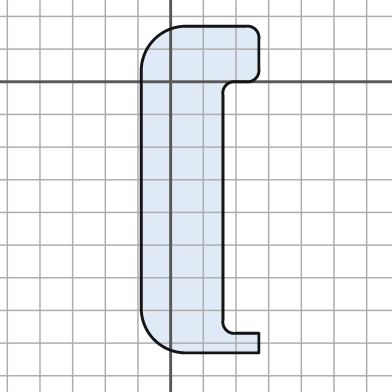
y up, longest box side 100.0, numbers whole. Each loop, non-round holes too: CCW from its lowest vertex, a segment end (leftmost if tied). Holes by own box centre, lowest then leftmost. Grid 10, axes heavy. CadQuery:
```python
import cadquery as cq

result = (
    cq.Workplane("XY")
    .moveTo(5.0, -83.0)
    .lineTo(27.0, -83.0)
    .lineTo(27.0, -77.0)
    .lineTo(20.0, -77.0)
    .threePointArc((17.0, -76.0), (16.0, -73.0))
    .lineTo(16.0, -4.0)
    .threePointArc((17.0, -1.0), (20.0, 0.0))
    .lineTo(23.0, 0.0)
    .threePointArc((26.0, 1.0), (27.0, 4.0))
    .lineTo(27.0, 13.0)
    .threePointArc((26.0, 16.0), (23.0, 17.0))
    .lineTo(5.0, 17.0)
    .threePointArc((-5.0, 13.0), (-9.0, 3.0))
    .lineTo(-9.0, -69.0)
    .threePointArc((-5.0, -79.0), (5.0, -83.0))
    .close()
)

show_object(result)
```